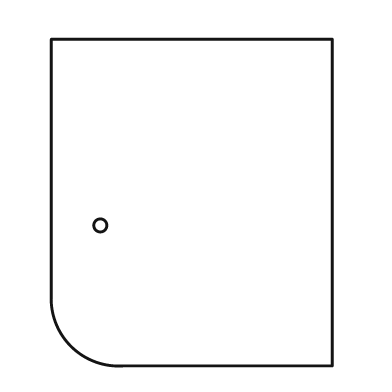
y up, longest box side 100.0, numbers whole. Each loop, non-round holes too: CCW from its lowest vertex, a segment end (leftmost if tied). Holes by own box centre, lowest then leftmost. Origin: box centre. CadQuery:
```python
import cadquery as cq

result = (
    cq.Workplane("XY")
    .moveTo(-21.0, -50.0)
    .lineTo(43.0, -50.0)
    .lineTo(43.0, 50.0)
    .lineTo(-43.0, 50.0)
    .lineTo(-43.0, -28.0)
    .threePointArc((-37.0, -44.0), (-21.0, -50.0))
    .close()
    .moveTo(-28.0, -7.0)
    .circle(2.0)
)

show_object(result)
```